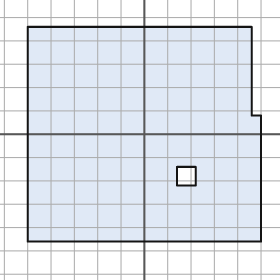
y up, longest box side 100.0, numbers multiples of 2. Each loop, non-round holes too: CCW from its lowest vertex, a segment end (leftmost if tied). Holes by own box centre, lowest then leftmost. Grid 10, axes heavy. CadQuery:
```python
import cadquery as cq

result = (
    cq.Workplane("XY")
    .moveTo(-50.0, -46.0)
    .lineTo(50.0, -46.0)
    .lineTo(50.0, 8.0)
    .lineTo(46.0, 8.0)
    .lineTo(46.0, 46.0)
    .lineTo(-50.0, 46.0)
    .close()
    .moveTo(14.0, -22.0)
    .lineTo(22.0, -22.0)
    .lineTo(22.0, -14.0)
    .lineTo(14.0, -14.0)
    .close()
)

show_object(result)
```